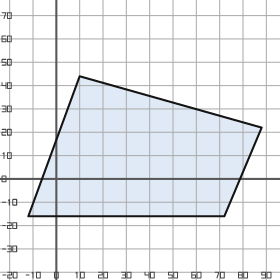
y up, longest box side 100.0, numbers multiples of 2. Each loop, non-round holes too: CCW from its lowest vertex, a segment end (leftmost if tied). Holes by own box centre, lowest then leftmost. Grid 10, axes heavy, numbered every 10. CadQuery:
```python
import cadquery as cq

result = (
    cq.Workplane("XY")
    .moveTo(-12.0, -16.0)
    .lineTo(72.0, -16.0)
    .lineTo(88.0, 22.0)
    .lineTo(10.0, 44.0)
    .close()
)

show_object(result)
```